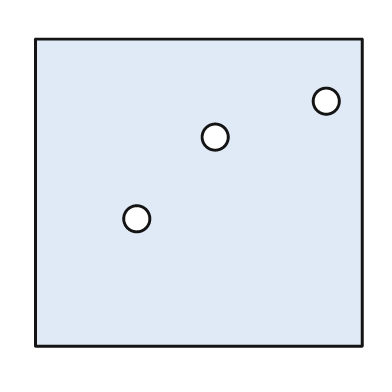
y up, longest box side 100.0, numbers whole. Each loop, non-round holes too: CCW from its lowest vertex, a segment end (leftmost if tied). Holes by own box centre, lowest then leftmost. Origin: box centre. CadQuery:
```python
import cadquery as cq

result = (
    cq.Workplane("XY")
    .moveTo(-50.0, -47.0)
    .lineTo(50.0, -47.0)
    .lineTo(50.0, 47.0)
    .lineTo(-50.0, 47.0)
    .close()
    .moveTo(-19.0, -8.0)
    .circle(4.0)
    .moveTo(5.0, 17.0)
    .circle(4.0)
    .moveTo(39.0, 28.0)
    .circle(4.0)
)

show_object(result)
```